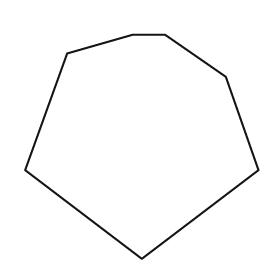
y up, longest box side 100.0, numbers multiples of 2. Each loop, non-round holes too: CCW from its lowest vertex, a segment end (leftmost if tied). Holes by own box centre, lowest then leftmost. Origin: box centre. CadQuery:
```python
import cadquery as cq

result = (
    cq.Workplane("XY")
    .moveTo(0.0, -48.0)
    .lineTo(50.0, -10.0)
    .lineTo(36.0, 30.0)
    .lineTo(10.0, 48.0)
    .lineTo(-4.0, 48.0)
    .lineTo(-32.0, 40.0)
    .lineTo(-50.0, -10.0)
    .close()
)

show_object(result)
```